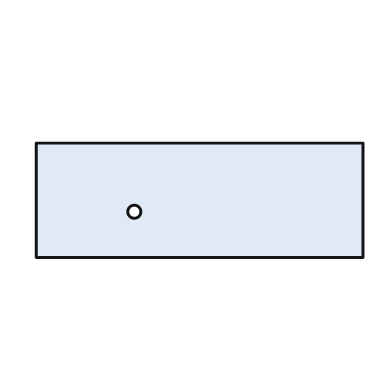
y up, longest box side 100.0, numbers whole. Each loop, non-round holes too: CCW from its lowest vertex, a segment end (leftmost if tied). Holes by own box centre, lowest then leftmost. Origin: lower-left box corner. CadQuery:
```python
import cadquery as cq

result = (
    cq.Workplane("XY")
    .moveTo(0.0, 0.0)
    .lineTo(100.0, 0.0)
    .lineTo(100.0, 35.0)
    .lineTo(0.0, 35.0)
    .close()
    .moveTo(30.0, 14.0)
    .circle(2.0)
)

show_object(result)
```